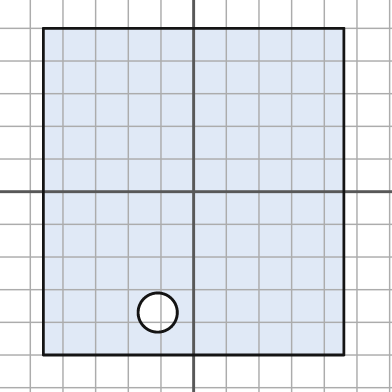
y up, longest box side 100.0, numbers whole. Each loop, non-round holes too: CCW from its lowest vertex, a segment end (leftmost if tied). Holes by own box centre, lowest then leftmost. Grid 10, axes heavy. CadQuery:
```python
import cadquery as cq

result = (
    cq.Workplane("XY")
    .moveTo(-46.0, -50.0)
    .lineTo(46.0, -50.0)
    .lineTo(46.0, 50.0)
    .lineTo(-46.0, 50.0)
    .close()
    .moveTo(-11.0, -37.0)
    .circle(6.0)
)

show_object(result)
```